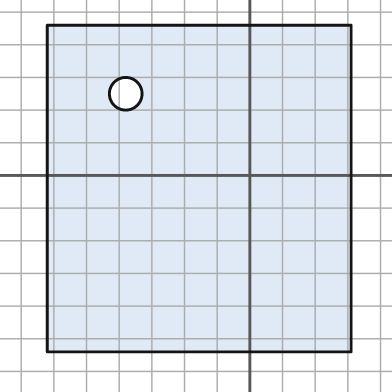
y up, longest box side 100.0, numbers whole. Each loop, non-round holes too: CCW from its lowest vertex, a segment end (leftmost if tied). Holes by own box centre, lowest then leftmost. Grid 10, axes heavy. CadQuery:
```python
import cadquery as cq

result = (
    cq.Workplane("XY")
    .moveTo(-62.0, -54.0)
    .lineTo(31.0, -54.0)
    .lineTo(31.0, 46.0)
    .lineTo(-62.0, 46.0)
    .close()
    .moveTo(-38.0, 25.0)
    .circle(5.0)
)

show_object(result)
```